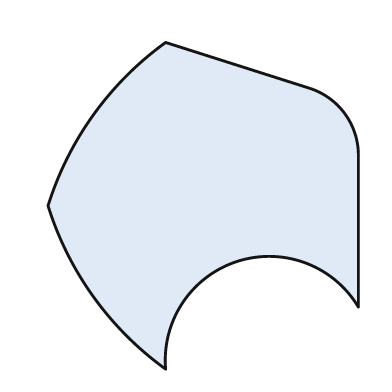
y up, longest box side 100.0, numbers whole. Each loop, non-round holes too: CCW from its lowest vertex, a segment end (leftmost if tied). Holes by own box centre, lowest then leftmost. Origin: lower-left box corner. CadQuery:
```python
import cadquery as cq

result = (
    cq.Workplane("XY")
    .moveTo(36.0, 0.0)
    .threePointArc((58.0, 33.0), (95.0, 19.0))
    .lineTo(95.0, 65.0)
    .threePointArc((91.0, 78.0), (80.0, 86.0))
    .lineTo(36.0, 100.0)
    .threePointArc((14.0, 78.0), (0.0, 50.0))
    .threePointArc((14.0, 22.0), (36.0, 0.0))
    .close()
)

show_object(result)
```